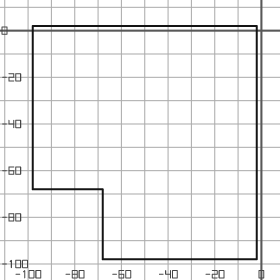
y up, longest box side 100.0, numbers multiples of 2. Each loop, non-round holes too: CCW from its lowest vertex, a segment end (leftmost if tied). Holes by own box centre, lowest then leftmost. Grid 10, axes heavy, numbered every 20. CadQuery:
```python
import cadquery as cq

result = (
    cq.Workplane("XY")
    .moveTo(-68.0, -98.0)
    .lineTo(-2.0, -98.0)
    .lineTo(-2.0, 2.0)
    .lineTo(-98.0, 2.0)
    .lineTo(-98.0, -68.0)
    .lineTo(-68.0, -68.0)
    .close()
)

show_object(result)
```